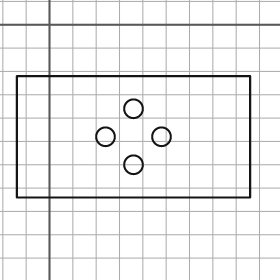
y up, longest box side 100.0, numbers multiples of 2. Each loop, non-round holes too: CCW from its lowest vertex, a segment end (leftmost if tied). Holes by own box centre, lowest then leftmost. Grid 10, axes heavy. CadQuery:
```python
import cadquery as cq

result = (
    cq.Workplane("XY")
    .moveTo(-14.0, -74.0)
    .lineTo(86.0, -74.0)
    .lineTo(86.0, -22.0)
    .lineTo(-14.0, -22.0)
    .close()
    .moveTo(36.0, -60.0)
    .circle(4.0)
    .moveTo(24.0, -48.0)
    .circle(4.0)
    .moveTo(48.0, -48.0)
    .circle(4.0)
    .moveTo(36.0, -36.0)
    .circle(4.0)
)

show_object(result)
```